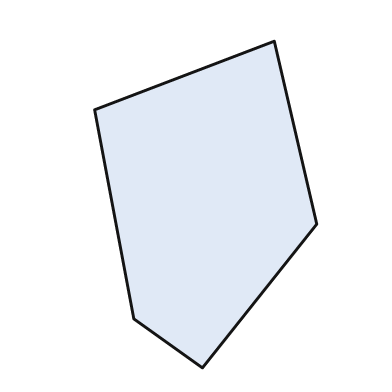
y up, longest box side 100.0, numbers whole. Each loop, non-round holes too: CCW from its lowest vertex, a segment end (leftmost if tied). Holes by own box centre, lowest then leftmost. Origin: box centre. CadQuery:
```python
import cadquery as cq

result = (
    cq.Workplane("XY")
    .moveTo(-1.0, -50.0)
    .lineTo(34.0, -6.0)
    .lineTo(21.0, 50.0)
    .lineTo(-34.0, 29.0)
    .lineTo(-22.0, -35.0)
    .close()
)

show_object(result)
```